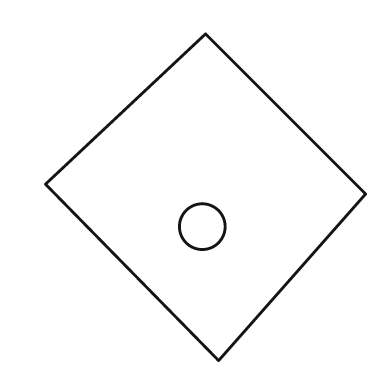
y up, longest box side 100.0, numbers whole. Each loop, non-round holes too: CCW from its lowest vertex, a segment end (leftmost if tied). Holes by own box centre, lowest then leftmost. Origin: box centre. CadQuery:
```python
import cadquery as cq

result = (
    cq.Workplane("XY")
    .moveTo(4.0, -50.0)
    .lineTo(49.0, 1.0)
    .lineTo(0.0, 50.0)
    .lineTo(-49.0, 4.0)
    .close()
    .moveTo(-1.0, -9.0)
    .circle(7.0)
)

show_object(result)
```